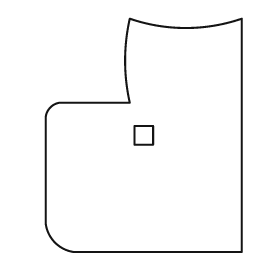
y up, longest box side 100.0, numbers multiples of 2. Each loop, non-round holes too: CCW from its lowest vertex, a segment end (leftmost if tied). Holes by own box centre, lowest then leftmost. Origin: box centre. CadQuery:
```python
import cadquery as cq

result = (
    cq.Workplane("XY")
    .moveTo(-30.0, -50.0)
    .lineTo(42.0, -50.0)
    .lineTo(42.0, 50.0)
    .threePointArc((18.0, 46.0), (-6.0, 50.0))
    .threePointArc((-8.0, 32.0), (-6.0, 14.0))
    .lineTo(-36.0, 14.0)
    .threePointArc((-40.0, 12.0), (-42.0, 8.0))
    .lineTo(-42.0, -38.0)
    .threePointArc((-38.0, -46.0), (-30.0, -50.0))
    .close()
    .moveTo(-4.0, -4.0)
    .lineTo(4.0, -4.0)
    .lineTo(4.0, 4.0)
    .lineTo(-4.0, 4.0)
    .close()
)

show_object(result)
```